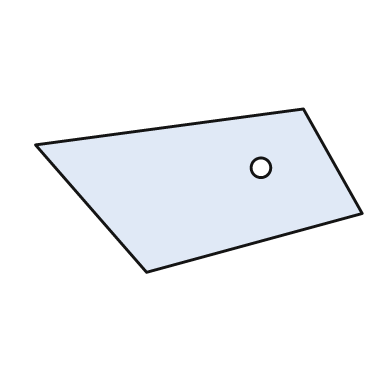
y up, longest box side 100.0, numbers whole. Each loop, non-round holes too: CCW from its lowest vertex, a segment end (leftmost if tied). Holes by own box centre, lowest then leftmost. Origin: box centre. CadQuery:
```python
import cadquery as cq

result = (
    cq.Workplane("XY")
    .moveTo(-16.0, -25.0)
    .lineTo(50.0, -7.0)
    .lineTo(32.0, 25.0)
    .lineTo(-50.0, 14.0)
    .close()
    .moveTo(19.0, 7.0)
    .circle(3.0)
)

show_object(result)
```